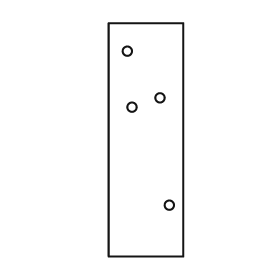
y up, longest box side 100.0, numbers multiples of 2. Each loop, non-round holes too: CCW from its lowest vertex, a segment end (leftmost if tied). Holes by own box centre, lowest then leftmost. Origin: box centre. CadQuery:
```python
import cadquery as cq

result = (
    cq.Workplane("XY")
    .moveTo(-16.0, -50.0)
    .lineTo(16.0, -50.0)
    .lineTo(16.0, 50.0)
    .lineTo(-16.0, 50.0)
    .close()
    .moveTo(10.0, -28.0)
    .circle(2.0)
    .moveTo(-6.0, 14.0)
    .circle(2.0)
    .moveTo(6.0, 18.0)
    .circle(2.0)
    .moveTo(-8.0, 38.0)
    .circle(2.0)
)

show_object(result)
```